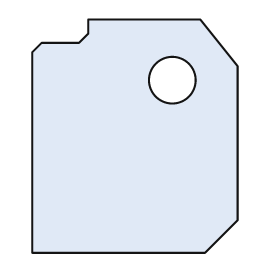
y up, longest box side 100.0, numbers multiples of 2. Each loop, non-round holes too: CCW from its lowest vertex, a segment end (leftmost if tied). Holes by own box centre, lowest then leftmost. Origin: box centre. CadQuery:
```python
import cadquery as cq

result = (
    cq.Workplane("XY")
    .moveTo(-44.0, -50.0)
    .lineTo(30.0, -50.0)
    .lineTo(44.0, -36.0)
    .lineTo(44.0, 30.0)
    .lineTo(28.0, 50.0)
    .lineTo(-20.0, 50.0)
    .lineTo(-20.0, 44.0)
    .lineTo(-24.0, 40.0)
    .lineTo(-40.0, 40.0)
    .lineTo(-44.0, 36.0)
    .close()
    .moveTo(16.0, 24.0)
    .circle(10.0)
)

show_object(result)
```